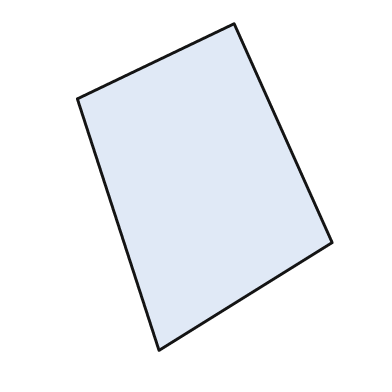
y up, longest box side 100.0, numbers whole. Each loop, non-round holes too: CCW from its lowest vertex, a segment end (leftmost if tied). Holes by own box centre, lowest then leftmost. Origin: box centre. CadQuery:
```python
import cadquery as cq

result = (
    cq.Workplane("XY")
    .moveTo(-14.0, -50.0)
    .lineTo(39.0, -17.0)
    .lineTo(9.0, 50.0)
    .lineTo(-39.0, 27.0)
    .close()
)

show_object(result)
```